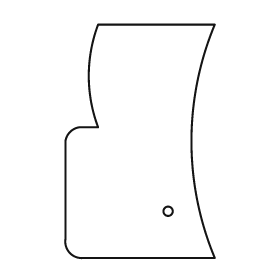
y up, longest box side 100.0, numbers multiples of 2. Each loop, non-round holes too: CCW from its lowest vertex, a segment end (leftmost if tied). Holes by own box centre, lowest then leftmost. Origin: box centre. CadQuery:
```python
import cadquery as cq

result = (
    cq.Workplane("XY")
    .moveTo(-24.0, -50.0)
    .lineTo(32.0, -50.0)
    .threePointArc((22.0, 0.0), (32.0, 50.0))
    .lineTo(-18.0, 50.0)
    .threePointArc((-22.0, 28.0), (-18.0, 6.0))
    .lineTo(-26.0, 6.0)
    .threePointArc((-30.0, 4.0), (-32.0, 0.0))
    .lineTo(-32.0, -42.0)
    .threePointArc((-30.0, -48.0), (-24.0, -50.0))
    .close()
    .moveTo(12.0, -30.0)
    .circle(2.0)
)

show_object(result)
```